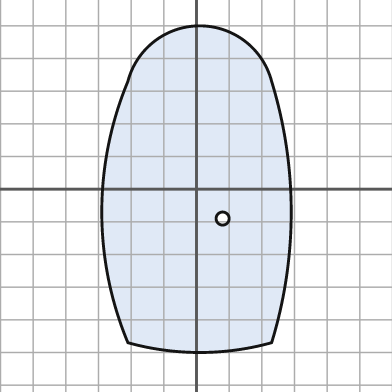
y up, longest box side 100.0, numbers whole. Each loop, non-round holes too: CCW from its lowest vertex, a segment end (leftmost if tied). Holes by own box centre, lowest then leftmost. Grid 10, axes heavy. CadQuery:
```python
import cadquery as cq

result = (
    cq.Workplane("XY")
    .moveTo(-21.0, -47.0)
    .threePointArc((1.0, -50.0), (23.0, -47.0))
    .threePointArc((29.0, -7.0), (23.0, 33.0))
    .threePointArc((1.0, 50.0), (-21.0, 33.0))
    .threePointArc((-29.0, -7.0), (-21.0, -47.0))
    .close()
    .moveTo(8.0, -9.0)
    .circle(2.0)
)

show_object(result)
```